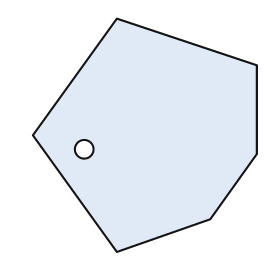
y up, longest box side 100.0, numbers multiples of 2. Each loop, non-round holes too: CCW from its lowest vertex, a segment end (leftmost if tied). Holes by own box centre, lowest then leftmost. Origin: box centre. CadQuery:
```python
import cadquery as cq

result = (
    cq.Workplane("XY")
    .moveTo(-12.0, -50.0)
    .lineTo(28.0, -36.0)
    .lineTo(48.0, -8.0)
    .lineTo(48.0, 30.0)
    .lineTo(-12.0, 50.0)
    .lineTo(-48.0, 0.0)
    .close()
    .moveTo(-26.0, -6.0)
    .circle(4.0)
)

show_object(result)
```